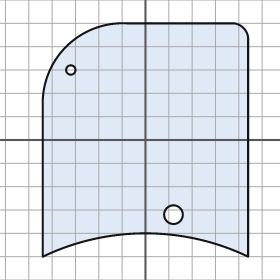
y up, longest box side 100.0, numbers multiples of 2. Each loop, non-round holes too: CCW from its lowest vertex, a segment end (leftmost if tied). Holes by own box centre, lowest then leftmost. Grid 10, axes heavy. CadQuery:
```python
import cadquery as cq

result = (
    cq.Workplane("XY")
    .moveTo(-44.0, -50.0)
    .threePointArc((0.0, -40.0), (44.0, -50.0))
    .lineTo(44.0, 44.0)
    .threePointArc((42.0, 48.0), (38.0, 50.0))
    .lineTo(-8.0, 50.0)
    .threePointArc((-34.0, 40.0), (-44.0, 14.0))
    .close()
    .moveTo(12.0, -32.0)
    .circle(4.0)
    .moveTo(-32.0, 30.0)
    .circle(2.0)
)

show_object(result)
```